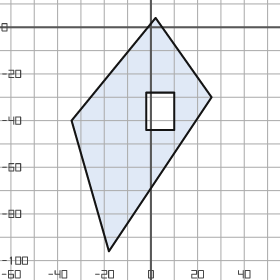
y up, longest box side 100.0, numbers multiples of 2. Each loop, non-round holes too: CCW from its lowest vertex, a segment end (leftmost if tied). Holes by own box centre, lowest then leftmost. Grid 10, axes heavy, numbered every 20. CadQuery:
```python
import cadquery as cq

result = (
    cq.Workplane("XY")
    .moveTo(-18.0, -96.0)
    .lineTo(26.0, -30.0)
    .lineTo(2.0, 4.0)
    .lineTo(-34.0, -40.0)
    .close()
    .moveTo(-2.0, -44.0)
    .lineTo(10.0, -44.0)
    .lineTo(10.0, -28.0)
    .lineTo(-2.0, -28.0)
    .close()
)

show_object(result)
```